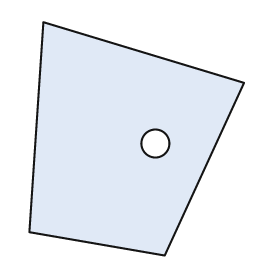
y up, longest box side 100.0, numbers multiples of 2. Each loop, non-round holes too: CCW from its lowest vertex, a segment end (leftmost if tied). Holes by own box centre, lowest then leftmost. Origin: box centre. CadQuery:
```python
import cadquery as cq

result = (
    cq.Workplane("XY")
    .moveTo(12.0, -50.0)
    .lineTo(46.0, 24.0)
    .lineTo(-40.0, 50.0)
    .lineTo(-46.0, -40.0)
    .close()
    .moveTo(8.0, -2.0)
    .circle(6.0)
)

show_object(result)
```